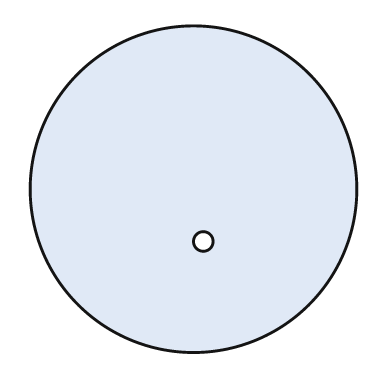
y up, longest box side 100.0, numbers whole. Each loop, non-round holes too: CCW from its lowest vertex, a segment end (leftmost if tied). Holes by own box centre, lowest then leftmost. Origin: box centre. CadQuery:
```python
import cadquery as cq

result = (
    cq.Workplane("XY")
    .moveTo(0.0, 0.0)
    .circle(50.0)
    .moveTo(3.0, -16.0)
    .circle(3.0)
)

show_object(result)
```